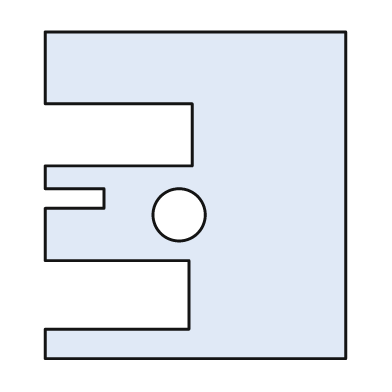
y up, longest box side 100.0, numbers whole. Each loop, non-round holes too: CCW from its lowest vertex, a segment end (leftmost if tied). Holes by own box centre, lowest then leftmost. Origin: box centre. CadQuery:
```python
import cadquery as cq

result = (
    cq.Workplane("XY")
    .moveTo(-46.0, -50.0)
    .lineTo(46.0, -50.0)
    .lineTo(46.0, 50.0)
    .lineTo(-46.0, 50.0)
    .lineTo(-46.0, 28.0)
    .lineTo(-1.0, 28.0)
    .lineTo(-1.0, 9.0)
    .lineTo(-46.0, 9.0)
    .lineTo(-46.0, 2.0)
    .lineTo(-28.0, 2.0)
    .lineTo(-28.0, -4.0)
    .lineTo(-46.0, -4.0)
    .lineTo(-46.0, -20.0)
    .lineTo(-2.0, -20.0)
    .lineTo(-2.0, -41.0)
    .lineTo(-46.0, -41.0)
    .close()
    .moveTo(-5.0, -6.0)
    .circle(8.0)
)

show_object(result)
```